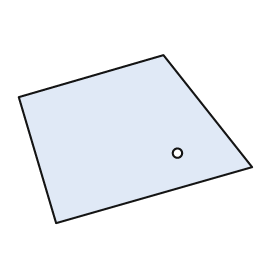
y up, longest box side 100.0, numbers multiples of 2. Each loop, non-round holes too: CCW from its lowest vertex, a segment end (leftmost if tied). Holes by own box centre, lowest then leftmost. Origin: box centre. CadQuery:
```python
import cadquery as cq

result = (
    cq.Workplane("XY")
    .moveTo(-34.0, -36.0)
    .lineTo(50.0, -12.0)
    .lineTo(12.0, 36.0)
    .lineTo(-50.0, 18.0)
    .close()
    .moveTo(18.0, -6.0)
    .circle(2.0)
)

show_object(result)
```